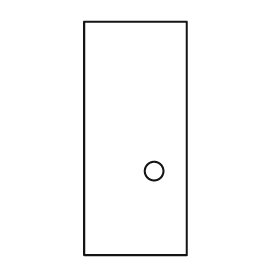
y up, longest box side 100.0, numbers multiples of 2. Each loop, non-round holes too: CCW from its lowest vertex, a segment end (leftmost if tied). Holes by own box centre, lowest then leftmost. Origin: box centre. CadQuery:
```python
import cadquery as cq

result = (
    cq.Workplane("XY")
    .moveTo(-22.0, -50.0)
    .lineTo(22.0, -50.0)
    .lineTo(22.0, 50.0)
    .lineTo(-22.0, 50.0)
    .close()
    .moveTo(8.0, -14.0)
    .circle(4.0)
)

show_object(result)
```